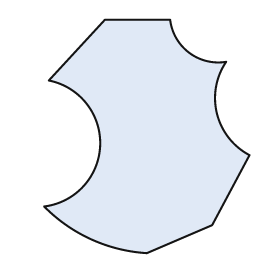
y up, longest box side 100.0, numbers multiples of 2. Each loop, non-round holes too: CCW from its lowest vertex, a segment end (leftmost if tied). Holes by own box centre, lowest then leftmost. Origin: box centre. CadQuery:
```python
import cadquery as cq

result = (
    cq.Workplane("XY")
    .moveTo(0.0, -50.0)
    .lineTo(28.0, -38.0)
    .lineTo(44.0, -8.0)
    .threePointArc((30.0, 10.0), (34.0, 32.0))
    .threePointArc((18.0, 36.0), (10.0, 50.0))
    .lineTo(-18.0, 50.0)
    .lineTo(-42.0, 24.0)
    .threePointArc((-20.0, -4.0), (-44.0, -30.0))
    .threePointArc((-24.0, -44.0), (0.0, -50.0))
    .close()
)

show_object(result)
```